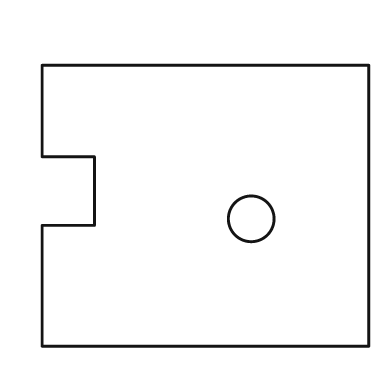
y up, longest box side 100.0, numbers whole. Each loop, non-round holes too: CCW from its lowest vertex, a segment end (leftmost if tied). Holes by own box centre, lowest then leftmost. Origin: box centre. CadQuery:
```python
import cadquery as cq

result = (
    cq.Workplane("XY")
    .moveTo(-50.0, -43.0)
    .lineTo(50.0, -43.0)
    .lineTo(50.0, 43.0)
    .lineTo(-50.0, 43.0)
    .lineTo(-50.0, 15.0)
    .lineTo(-34.0, 15.0)
    .lineTo(-34.0, -6.0)
    .lineTo(-50.0, -6.0)
    .close()
    .moveTo(14.0, -4.0)
    .circle(7.0)
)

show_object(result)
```